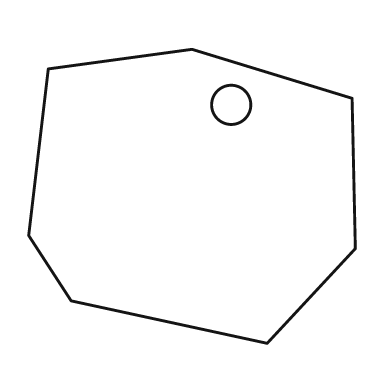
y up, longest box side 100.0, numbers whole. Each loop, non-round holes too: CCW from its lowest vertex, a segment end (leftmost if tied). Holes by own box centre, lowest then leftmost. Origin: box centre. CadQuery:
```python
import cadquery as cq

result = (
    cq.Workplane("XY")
    .moveTo(23.0, -45.0)
    .lineTo(50.0, -16.0)
    .lineTo(49.0, 30.0)
    .lineTo(0.0, 45.0)
    .lineTo(-44.0, 39.0)
    .lineTo(-50.0, -12.0)
    .lineTo(-37.0, -32.0)
    .close()
    .moveTo(12.0, 28.0)
    .circle(6.0)
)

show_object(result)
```